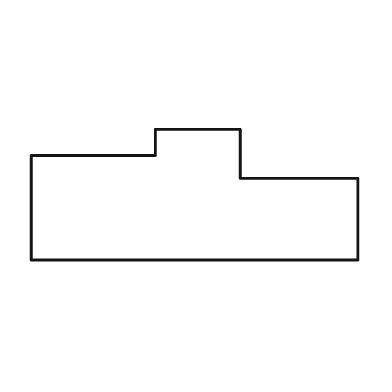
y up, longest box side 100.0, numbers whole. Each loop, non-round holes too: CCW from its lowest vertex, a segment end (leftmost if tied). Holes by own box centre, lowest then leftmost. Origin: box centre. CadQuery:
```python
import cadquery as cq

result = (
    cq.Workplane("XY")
    .moveTo(-50.0, -20.0)
    .lineTo(50.0, -20.0)
    .lineTo(50.0, 5.0)
    .lineTo(14.0, 5.0)
    .lineTo(14.0, 20.0)
    .lineTo(-12.0, 20.0)
    .lineTo(-12.0, 12.0)
    .lineTo(-50.0, 12.0)
    .close()
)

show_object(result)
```